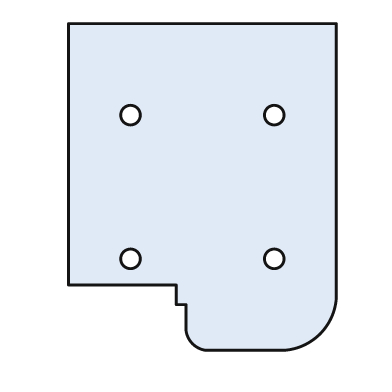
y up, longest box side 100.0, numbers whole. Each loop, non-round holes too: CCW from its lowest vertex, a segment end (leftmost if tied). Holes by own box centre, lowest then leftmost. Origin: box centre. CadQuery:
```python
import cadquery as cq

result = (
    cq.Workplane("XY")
    .moveTo(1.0, -50.0)
    .lineTo(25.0, -50.0)
    .threePointArc((36.0, -45.0), (41.0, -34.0))
    .lineTo(41.0, 50.0)
    .lineTo(-41.0, 50.0)
    .lineTo(-41.0, -30.0)
    .lineTo(-8.0, -30.0)
    .lineTo(-8.0, -36.0)
    .lineTo(-5.0, -36.0)
    .lineTo(-5.0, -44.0)
    .threePointArc((-3.0, -48.0), (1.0, -50.0))
    .close()
    .moveTo(-22.0, -22.0)
    .circle(3.0)
    .moveTo(22.0, -22.0)
    .circle(3.0)
    .moveTo(-22.0, 22.0)
    .circle(3.0)
    .moveTo(22.0, 22.0)
    .circle(3.0)
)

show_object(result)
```